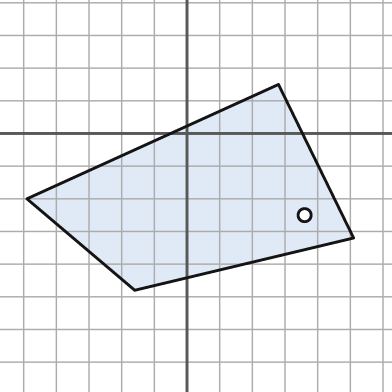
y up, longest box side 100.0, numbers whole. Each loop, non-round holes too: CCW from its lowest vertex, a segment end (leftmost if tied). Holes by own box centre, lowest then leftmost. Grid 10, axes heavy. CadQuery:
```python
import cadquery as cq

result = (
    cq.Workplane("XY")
    .moveTo(-16.0, -48.0)
    .lineTo(51.0, -32.0)
    .lineTo(28.0, 15.0)
    .lineTo(-49.0, -20.0)
    .close()
    .moveTo(36.0, -25.0)
    .circle(2.0)
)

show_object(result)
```